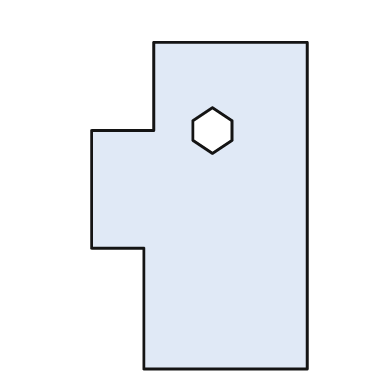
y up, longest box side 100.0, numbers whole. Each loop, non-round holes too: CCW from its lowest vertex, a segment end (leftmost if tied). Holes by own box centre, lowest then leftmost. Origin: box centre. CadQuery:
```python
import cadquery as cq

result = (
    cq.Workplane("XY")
    .moveTo(-17.0, -50.0)
    .lineTo(33.0, -50.0)
    .lineTo(33.0, 50.0)
    .lineTo(-14.0, 50.0)
    .lineTo(-14.0, 23.0)
    .lineTo(-33.0, 23.0)
    .lineTo(-33.0, -13.0)
    .lineTo(-17.0, -13.0)
    .close()
    .moveTo(4.0, 16.0)
    .lineTo(10.0, 20.0)
    .lineTo(10.0, 26.0)
    .lineTo(4.0, 30.0)
    .lineTo(-2.0, 26.0)
    .lineTo(-2.0, 20.0)
    .close()
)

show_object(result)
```